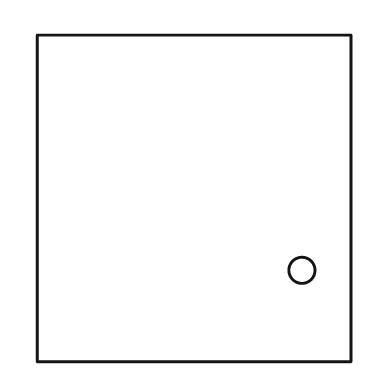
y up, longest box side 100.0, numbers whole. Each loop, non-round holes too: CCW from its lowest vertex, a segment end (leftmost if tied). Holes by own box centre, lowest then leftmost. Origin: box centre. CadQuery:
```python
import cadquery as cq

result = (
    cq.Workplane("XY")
    .moveTo(-48.0, -50.0)
    .lineTo(48.0, -50.0)
    .lineTo(48.0, 50.0)
    .lineTo(-48.0, 50.0)
    .close()
    .moveTo(33.0, -22.0)
    .circle(4.0)
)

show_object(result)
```